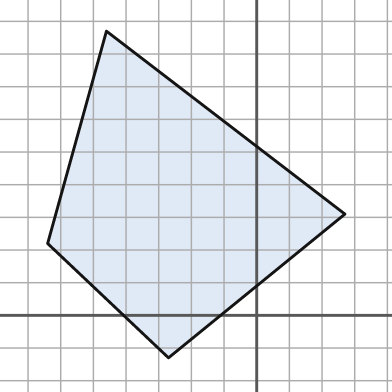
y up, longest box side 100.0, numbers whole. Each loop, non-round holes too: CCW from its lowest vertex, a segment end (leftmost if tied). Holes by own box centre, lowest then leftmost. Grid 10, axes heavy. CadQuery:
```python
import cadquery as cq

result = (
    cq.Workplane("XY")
    .moveTo(-27.0, -13.0)
    .lineTo(27.0, 31.0)
    .lineTo(-46.0, 87.0)
    .lineTo(-64.0, 22.0)
    .close()
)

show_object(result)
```